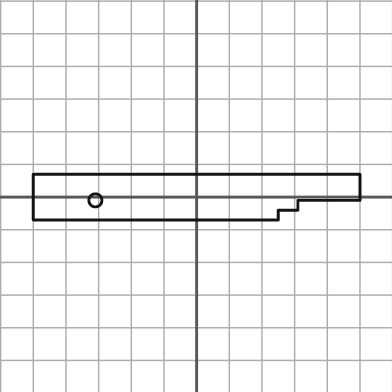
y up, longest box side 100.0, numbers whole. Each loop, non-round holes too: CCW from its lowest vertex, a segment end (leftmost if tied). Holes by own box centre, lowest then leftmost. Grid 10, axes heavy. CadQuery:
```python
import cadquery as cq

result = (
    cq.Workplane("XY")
    .moveTo(-50.0, -7.0)
    .lineTo(25.0, -7.0)
    .lineTo(25.0, -4.0)
    .lineTo(31.0, -4.0)
    .lineTo(31.0, -1.0)
    .lineTo(50.0, -1.0)
    .lineTo(50.0, 7.0)
    .lineTo(-50.0, 7.0)
    .close()
    .moveTo(-31.0, -1.0)
    .circle(2.0)
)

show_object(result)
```